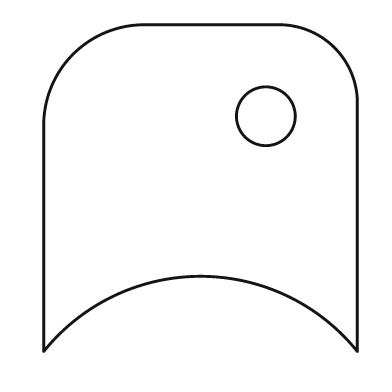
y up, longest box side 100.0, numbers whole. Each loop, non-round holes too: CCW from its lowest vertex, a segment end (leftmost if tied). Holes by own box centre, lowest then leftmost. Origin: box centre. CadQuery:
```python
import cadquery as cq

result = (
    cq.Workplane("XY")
    .moveTo(-48.0, -50.0)
    .threePointArc((0.0, -27.0), (48.0, -50.0))
    .lineTo(48.0, 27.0)
    .threePointArc((41.0, 43.0), (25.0, 50.0))
    .lineTo(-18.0, 50.0)
    .threePointArc((-39.0, 41.0), (-48.0, 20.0))
    .close()
    .moveTo(20.0, 22.0)
    .circle(9.0)
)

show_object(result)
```